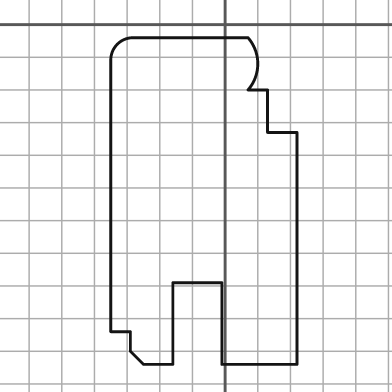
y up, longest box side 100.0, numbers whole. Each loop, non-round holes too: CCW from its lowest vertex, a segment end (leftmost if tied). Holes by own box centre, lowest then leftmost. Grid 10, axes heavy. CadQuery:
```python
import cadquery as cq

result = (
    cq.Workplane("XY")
    .moveTo(-25.0, -104.0)
    .lineTo(-16.0, -104.0)
    .lineTo(-16.0, -79.0)
    .lineTo(-1.0, -79.0)
    .lineTo(-1.0, -104.0)
    .lineTo(22.0, -104.0)
    .lineTo(22.0, -33.0)
    .lineTo(13.0, -33.0)
    .lineTo(13.0, -20.0)
    .lineTo(7.0, -20.0)
    .threePointArc((10.0, -12.0), (7.0, -4.0))
    .lineTo(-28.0, -4.0)
    .threePointArc((-33.0, -6.0), (-35.0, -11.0))
    .lineTo(-35.0, -94.0)
    .lineTo(-29.0, -94.0)
    .lineTo(-29.0, -100.0)
    .close()
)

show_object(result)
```